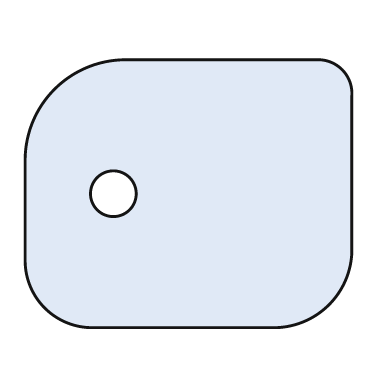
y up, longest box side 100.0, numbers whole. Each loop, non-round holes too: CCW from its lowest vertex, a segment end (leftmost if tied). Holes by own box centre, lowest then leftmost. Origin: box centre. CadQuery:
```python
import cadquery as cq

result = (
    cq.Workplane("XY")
    .moveTo(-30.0, -41.0)
    .lineTo(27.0, -41.0)
    .threePointArc((43.0, -34.0), (50.0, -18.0))
    .lineTo(50.0, 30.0)
    .threePointArc((47.0, 38.0), (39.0, 41.0))
    .lineTo(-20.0, 41.0)
    .threePointArc((-41.0, 32.0), (-50.0, 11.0))
    .lineTo(-50.0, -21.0)
    .threePointArc((-44.0, -35.0), (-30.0, -41.0))
    .close()
    .moveTo(-23.0, 0.0)
    .circle(7.0)
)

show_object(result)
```